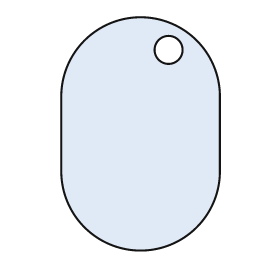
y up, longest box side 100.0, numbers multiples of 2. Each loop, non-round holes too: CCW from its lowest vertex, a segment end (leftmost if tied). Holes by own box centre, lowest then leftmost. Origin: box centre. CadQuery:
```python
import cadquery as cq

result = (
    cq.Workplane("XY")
    .moveTo(-34.0, -16.0)
    .threePointArc((0.0, -50.0), (34.0, -16.0))
    .lineTo(34.0, 16.0)
    .threePointArc((0.0, 50.0), (-34.0, 16.0))
    .close()
    .moveTo(12.0, 36.0)
    .circle(6.0)
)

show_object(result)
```